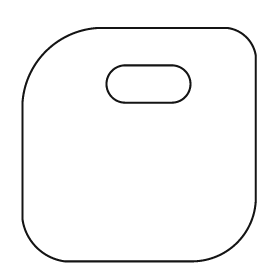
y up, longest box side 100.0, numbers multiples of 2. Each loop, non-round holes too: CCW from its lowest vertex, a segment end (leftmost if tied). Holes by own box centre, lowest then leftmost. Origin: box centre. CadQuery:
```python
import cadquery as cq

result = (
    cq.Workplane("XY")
    .moveTo(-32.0, -50.0)
    .lineTo(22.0, -50.0)
    .threePointArc((42.0, -42.0), (50.0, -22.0))
    .lineTo(50.0, 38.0)
    .threePointArc((46.0, 46.0), (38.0, 50.0))
    .lineTo(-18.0, 50.0)
    .threePointArc((-40.0, 40.0), (-50.0, 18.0))
    .lineTo(-50.0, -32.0)
    .threePointArc((-44.0, -44.0), (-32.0, -50.0))
    .close()
    .moveTo(-6.0, 18.0)
    .lineTo(14.0, 18.0)
    .threePointArc((22.0, 26.0), (14.0, 34.0))
    .lineTo(-6.0, 34.0)
    .threePointArc((-14.0, 26.0), (-6.0, 18.0))
    .close()
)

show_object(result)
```